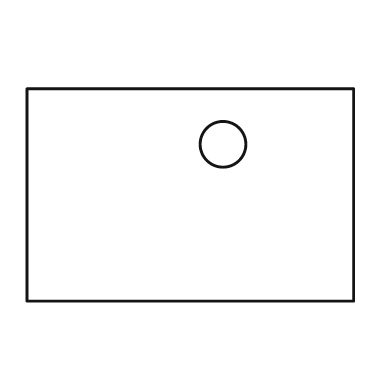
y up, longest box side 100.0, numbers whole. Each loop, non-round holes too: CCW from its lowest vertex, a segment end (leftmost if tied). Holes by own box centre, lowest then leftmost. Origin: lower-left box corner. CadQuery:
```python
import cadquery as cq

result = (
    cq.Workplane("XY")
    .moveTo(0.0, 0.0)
    .lineTo(100.0, 0.0)
    .lineTo(100.0, 65.0)
    .lineTo(0.0, 65.0)
    .close()
    .moveTo(60.0, 48.0)
    .circle(7.0)
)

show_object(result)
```